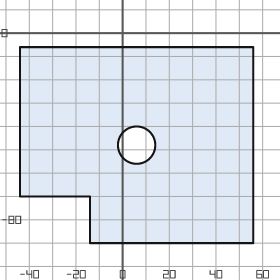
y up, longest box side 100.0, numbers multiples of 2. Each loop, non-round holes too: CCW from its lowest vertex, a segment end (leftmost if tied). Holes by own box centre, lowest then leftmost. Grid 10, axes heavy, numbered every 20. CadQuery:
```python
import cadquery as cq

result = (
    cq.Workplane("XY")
    .moveTo(-14.0, -90.0)
    .lineTo(56.0, -90.0)
    .lineTo(56.0, -6.0)
    .lineTo(-44.0, -6.0)
    .lineTo(-44.0, -70.0)
    .lineTo(-14.0, -70.0)
    .close()
    .moveTo(6.0, -48.0)
    .circle(8.0)
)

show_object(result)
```